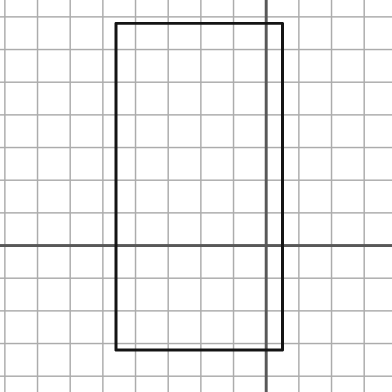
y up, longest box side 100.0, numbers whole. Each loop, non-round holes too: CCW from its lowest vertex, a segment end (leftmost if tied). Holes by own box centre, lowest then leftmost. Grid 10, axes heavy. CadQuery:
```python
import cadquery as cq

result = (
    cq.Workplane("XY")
    .moveTo(-46.0, -32.0)
    .lineTo(5.0, -32.0)
    .lineTo(5.0, 68.0)
    .lineTo(-46.0, 68.0)
    .close()
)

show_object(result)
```